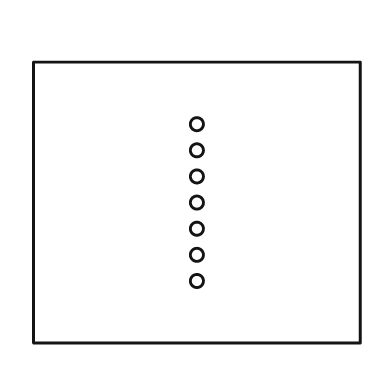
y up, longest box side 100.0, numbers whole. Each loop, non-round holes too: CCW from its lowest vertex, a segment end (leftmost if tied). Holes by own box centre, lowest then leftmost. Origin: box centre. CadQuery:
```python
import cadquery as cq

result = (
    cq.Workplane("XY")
    .moveTo(-50.0, -43.0)
    .lineTo(50.0, -43.0)
    .lineTo(50.0, 43.0)
    .lineTo(-50.0, 43.0)
    .close()
    .moveTo(0.0, -24.0)
    .circle(2.0)
    .moveTo(0.0, -16.0)
    .circle(2.0)
    .moveTo(0.0, -8.0)
    .circle(2.0)
    .moveTo(0.0, 0.0)
    .circle(2.0)
    .moveTo(0.0, 8.0)
    .circle(2.0)
    .moveTo(0.0, 16.0)
    .circle(2.0)
    .moveTo(0.0, 24.0)
    .circle(2.0)
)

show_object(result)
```